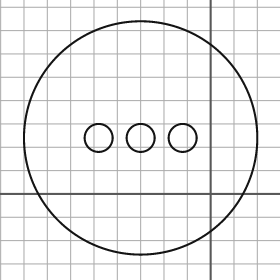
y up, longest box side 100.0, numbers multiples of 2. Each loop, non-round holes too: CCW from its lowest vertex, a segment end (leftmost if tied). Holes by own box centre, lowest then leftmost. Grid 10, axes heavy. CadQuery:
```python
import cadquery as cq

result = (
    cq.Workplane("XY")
    .moveTo(-30.0, 24.0)
    .circle(50.0)
    .moveTo(-48.0, 24.0)
    .circle(6.0)
    .moveTo(-30.0, 24.0)
    .circle(6.0)
    .moveTo(-12.0, 24.0)
    .circle(6.0)
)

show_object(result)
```